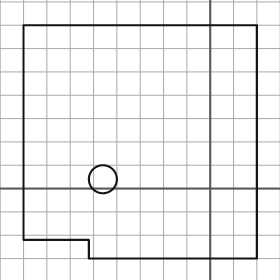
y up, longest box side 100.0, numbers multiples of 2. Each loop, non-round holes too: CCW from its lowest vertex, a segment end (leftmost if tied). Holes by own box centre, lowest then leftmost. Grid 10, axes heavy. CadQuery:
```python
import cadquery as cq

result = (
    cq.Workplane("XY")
    .moveTo(-52.0, -30.0)
    .lineTo(20.0, -30.0)
    .lineTo(20.0, 70.0)
    .lineTo(-80.0, 70.0)
    .lineTo(-80.0, -22.0)
    .lineTo(-52.0, -22.0)
    .close()
    .moveTo(-46.0, 4.0)
    .circle(6.0)
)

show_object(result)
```